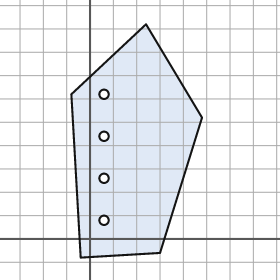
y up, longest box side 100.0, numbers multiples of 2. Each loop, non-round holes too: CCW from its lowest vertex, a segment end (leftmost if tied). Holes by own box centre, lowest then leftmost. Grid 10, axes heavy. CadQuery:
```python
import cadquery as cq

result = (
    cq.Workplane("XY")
    .moveTo(-4.0, -8.0)
    .lineTo(30.0, -6.0)
    .lineTo(48.0, 52.0)
    .lineTo(24.0, 92.0)
    .lineTo(-8.0, 62.0)
    .close()
    .moveTo(6.0, 8.0)
    .circle(2.0)
    .moveTo(6.0, 26.0)
    .circle(2.0)
    .moveTo(6.0, 44.0)
    .circle(2.0)
    .moveTo(6.0, 62.0)
    .circle(2.0)
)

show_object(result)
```